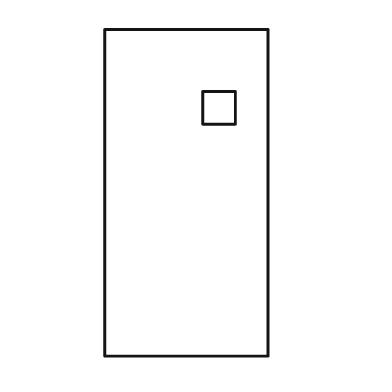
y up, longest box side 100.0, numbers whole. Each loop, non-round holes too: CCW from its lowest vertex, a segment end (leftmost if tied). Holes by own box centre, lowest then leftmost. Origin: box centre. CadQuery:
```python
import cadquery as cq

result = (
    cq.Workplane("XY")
    .moveTo(-25.0, -50.0)
    .lineTo(25.0, -50.0)
    .lineTo(25.0, 50.0)
    .lineTo(-25.0, 50.0)
    .close()
    .moveTo(5.0, 21.0)
    .lineTo(15.0, 21.0)
    .lineTo(15.0, 31.0)
    .lineTo(5.0, 31.0)
    .close()
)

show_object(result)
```